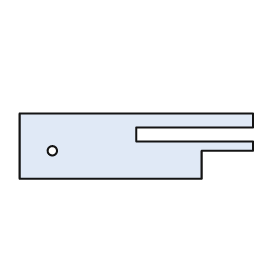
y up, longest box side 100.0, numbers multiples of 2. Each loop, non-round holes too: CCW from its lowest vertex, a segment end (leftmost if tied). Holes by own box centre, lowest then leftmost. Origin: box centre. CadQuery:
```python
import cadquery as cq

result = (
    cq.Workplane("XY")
    .moveTo(-50.0, -14.0)
    .lineTo(28.0, -14.0)
    .lineTo(28.0, -2.0)
    .lineTo(50.0, -2.0)
    .lineTo(50.0, 2.0)
    .lineTo(0.0, 2.0)
    .lineTo(0.0, 8.0)
    .lineTo(50.0, 8.0)
    .lineTo(50.0, 14.0)
    .lineTo(-50.0, 14.0)
    .close()
    .moveTo(-36.0, -2.0)
    .circle(2.0)
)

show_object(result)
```